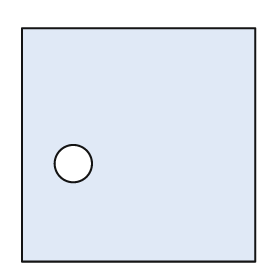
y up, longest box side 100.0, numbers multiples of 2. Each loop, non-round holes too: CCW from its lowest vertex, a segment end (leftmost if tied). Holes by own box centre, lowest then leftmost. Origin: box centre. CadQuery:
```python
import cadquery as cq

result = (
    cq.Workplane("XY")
    .moveTo(-50.0, -50.0)
    .lineTo(50.0, -50.0)
    .lineTo(50.0, 50.0)
    .lineTo(-50.0, 50.0)
    .close()
    .moveTo(-28.0, -8.0)
    .circle(8.0)
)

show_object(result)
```